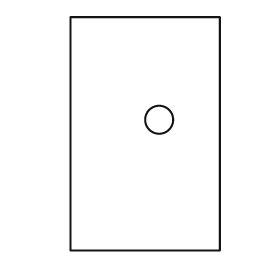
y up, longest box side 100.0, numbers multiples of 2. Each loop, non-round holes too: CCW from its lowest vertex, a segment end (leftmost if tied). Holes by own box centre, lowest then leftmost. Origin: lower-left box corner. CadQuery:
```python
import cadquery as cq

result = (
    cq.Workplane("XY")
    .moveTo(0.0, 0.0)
    .lineTo(64.0, 0.0)
    .lineTo(64.0, 100.0)
    .lineTo(0.0, 100.0)
    .close()
    .moveTo(38.0, 56.0)
    .circle(6.0)
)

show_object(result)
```